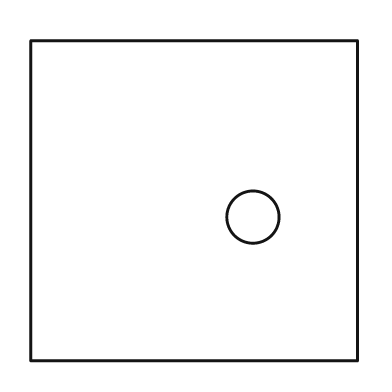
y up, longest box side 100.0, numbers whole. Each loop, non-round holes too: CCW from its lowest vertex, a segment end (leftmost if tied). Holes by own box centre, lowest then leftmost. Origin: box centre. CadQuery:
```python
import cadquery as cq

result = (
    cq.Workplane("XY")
    .moveTo(-50.0, -49.0)
    .lineTo(50.0, -49.0)
    .lineTo(50.0, 49.0)
    .lineTo(-50.0, 49.0)
    .close()
    .moveTo(18.0, -5.0)
    .circle(8.0)
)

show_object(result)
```